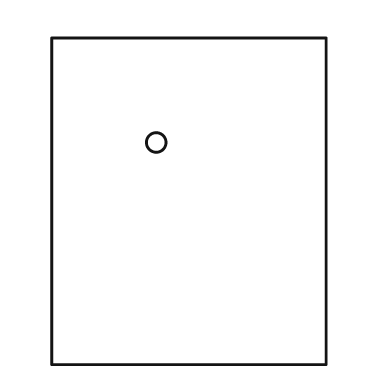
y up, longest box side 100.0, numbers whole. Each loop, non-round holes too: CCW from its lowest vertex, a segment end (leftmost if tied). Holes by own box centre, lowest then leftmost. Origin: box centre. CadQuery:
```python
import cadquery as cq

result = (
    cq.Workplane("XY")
    .moveTo(-42.0, -50.0)
    .lineTo(42.0, -50.0)
    .lineTo(42.0, 50.0)
    .lineTo(-42.0, 50.0)
    .close()
    .moveTo(-10.0, 18.0)
    .circle(3.0)
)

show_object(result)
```